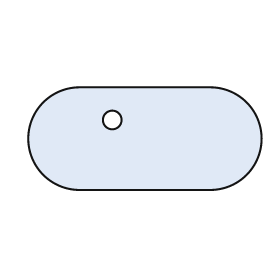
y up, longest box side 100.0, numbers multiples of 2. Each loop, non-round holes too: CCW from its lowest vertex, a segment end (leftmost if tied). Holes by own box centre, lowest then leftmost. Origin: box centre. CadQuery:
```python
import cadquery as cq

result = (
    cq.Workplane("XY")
    .moveTo(-28.0, -22.0)
    .lineTo(28.0, -22.0)
    .threePointArc((50.0, 0.0), (28.0, 22.0))
    .lineTo(-28.0, 22.0)
    .threePointArc((-50.0, 0.0), (-28.0, -22.0))
    .close()
    .moveTo(-14.0, 8.0)
    .circle(4.0)
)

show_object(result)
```